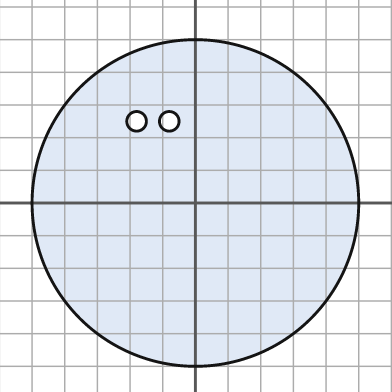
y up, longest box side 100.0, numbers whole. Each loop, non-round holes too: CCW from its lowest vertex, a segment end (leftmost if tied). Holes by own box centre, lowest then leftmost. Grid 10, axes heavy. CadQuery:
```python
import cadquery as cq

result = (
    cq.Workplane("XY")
    .moveTo(0.0, 0.0)
    .circle(50.0)
    .moveTo(-18.0, 25.0)
    .circle(3.0)
    .moveTo(-8.0, 25.0)
    .circle(3.0)
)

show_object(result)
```